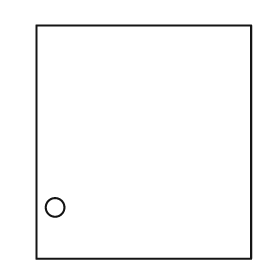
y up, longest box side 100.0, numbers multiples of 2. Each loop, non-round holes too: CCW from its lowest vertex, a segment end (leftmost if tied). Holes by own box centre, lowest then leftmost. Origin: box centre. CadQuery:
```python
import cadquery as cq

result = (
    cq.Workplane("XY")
    .moveTo(-46.0, -50.0)
    .lineTo(46.0, -50.0)
    .lineTo(46.0, 50.0)
    .lineTo(-46.0, 50.0)
    .close()
    .moveTo(-38.0, -28.0)
    .circle(4.0)
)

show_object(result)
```